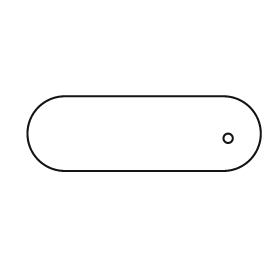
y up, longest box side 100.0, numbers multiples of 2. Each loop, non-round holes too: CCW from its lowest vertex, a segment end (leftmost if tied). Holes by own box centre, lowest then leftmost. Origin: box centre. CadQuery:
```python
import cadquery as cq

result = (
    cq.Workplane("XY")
    .moveTo(-34.0, -16.0)
    .lineTo(34.0, -16.0)
    .threePointArc((50.0, 0.0), (34.0, 16.0))
    .lineTo(-34.0, 16.0)
    .threePointArc((-50.0, 0.0), (-34.0, -16.0))
    .close()
    .moveTo(36.0, -2.0)
    .circle(2.0)
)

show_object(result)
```